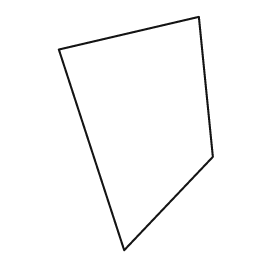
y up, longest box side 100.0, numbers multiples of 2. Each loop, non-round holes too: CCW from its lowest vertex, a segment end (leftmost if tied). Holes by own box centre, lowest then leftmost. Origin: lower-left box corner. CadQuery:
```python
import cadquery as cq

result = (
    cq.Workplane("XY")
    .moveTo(28.0, 0.0)
    .lineTo(66.0, 40.0)
    .lineTo(60.0, 100.0)
    .lineTo(0.0, 86.0)
    .close()
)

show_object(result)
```